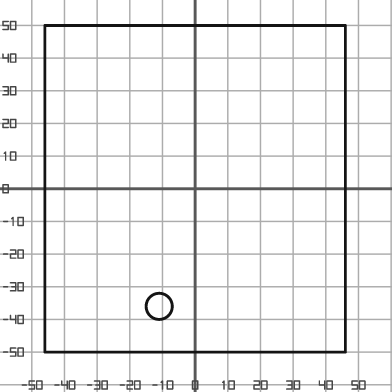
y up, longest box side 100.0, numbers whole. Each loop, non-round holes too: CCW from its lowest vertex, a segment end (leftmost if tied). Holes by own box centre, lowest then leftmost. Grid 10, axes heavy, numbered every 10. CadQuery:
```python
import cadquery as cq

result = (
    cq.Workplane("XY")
    .moveTo(-46.0, -50.0)
    .lineTo(46.0, -50.0)
    .lineTo(46.0, 50.0)
    .lineTo(-46.0, 50.0)
    .close()
    .moveTo(-11.0, -36.0)
    .circle(4.0)
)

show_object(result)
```